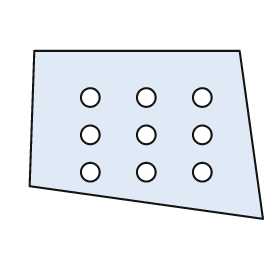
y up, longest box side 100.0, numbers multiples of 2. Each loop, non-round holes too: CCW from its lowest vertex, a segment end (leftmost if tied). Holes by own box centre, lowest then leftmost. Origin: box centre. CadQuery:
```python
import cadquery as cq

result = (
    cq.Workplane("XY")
    .moveTo(50.0, -36.0)
    .lineTo(40.0, 36.0)
    .lineTo(-48.0, 36.0)
    .lineTo(-50.0, -22.0)
    .close()
    .moveTo(-24.0, -16.0)
    .circle(4.0)
    .moveTo(0.0, -16.0)
    .circle(4.0)
    .moveTo(24.0, -16.0)
    .circle(4.0)
    .moveTo(-24.0, 0.0)
    .circle(4.0)
    .moveTo(0.0, 0.0)
    .circle(4.0)
    .moveTo(24.0, 0.0)
    .circle(4.0)
    .moveTo(-24.0, 16.0)
    .circle(4.0)
    .moveTo(0.0, 16.0)
    .circle(4.0)
    .moveTo(24.0, 16.0)
    .circle(4.0)
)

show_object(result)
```